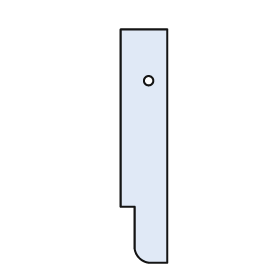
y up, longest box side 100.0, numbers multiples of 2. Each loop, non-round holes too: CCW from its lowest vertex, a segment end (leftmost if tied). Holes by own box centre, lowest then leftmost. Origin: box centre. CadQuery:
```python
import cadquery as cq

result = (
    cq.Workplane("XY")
    .moveTo(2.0, -50.0)
    .lineTo(10.0, -50.0)
    .lineTo(10.0, 50.0)
    .lineTo(-10.0, 50.0)
    .lineTo(-10.0, -26.0)
    .lineTo(-4.0, -26.0)
    .lineTo(-4.0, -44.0)
    .threePointArc((-2.0, -48.0), (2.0, -50.0))
    .close()
    .moveTo(2.0, 28.0)
    .circle(2.0)
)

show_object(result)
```